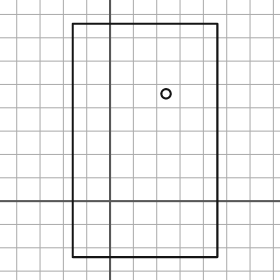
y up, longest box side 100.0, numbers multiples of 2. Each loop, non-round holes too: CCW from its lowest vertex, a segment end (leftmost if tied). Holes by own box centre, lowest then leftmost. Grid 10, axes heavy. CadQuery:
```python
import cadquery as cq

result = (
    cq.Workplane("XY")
    .moveTo(-16.0, -24.0)
    .lineTo(46.0, -24.0)
    .lineTo(46.0, 76.0)
    .lineTo(-16.0, 76.0)
    .close()
    .moveTo(24.0, 46.0)
    .circle(2.0)
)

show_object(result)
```